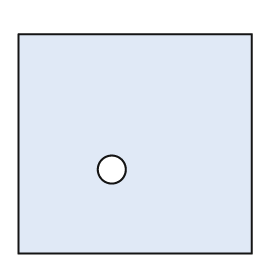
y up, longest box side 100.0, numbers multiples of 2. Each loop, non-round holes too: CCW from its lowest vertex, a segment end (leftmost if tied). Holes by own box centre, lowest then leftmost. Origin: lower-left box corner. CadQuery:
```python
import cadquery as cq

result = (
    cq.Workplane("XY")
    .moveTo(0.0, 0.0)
    .lineTo(100.0, 0.0)
    .lineTo(100.0, 94.0)
    .lineTo(0.0, 94.0)
    .close()
    .moveTo(40.0, 36.0)
    .circle(6.0)
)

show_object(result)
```